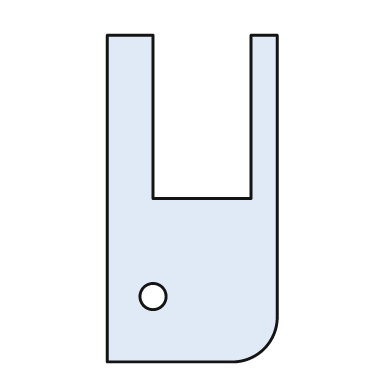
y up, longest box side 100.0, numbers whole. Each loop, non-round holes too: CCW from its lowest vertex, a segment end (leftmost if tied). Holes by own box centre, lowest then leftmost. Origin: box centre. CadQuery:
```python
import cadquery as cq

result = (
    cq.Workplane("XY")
    .moveTo(-26.0, -50.0)
    .lineTo(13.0, -50.0)
    .threePointArc((22.0, -46.0), (26.0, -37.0))
    .lineTo(26.0, 50.0)
    .lineTo(18.0, 50.0)
    .lineTo(18.0, 0.0)
    .lineTo(-12.0, 0.0)
    .lineTo(-12.0, 50.0)
    .lineTo(-26.0, 50.0)
    .close()
    .moveTo(-12.0, -30.0)
    .circle(4.0)
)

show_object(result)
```